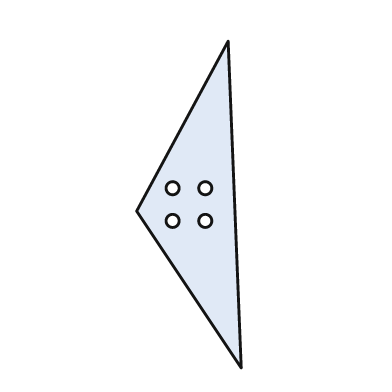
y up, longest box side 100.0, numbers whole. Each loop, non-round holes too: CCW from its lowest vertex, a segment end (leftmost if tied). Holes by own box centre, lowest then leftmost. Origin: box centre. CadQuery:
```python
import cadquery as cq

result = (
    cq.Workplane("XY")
    .moveTo(16.0, -50.0)
    .lineTo(12.0, 50.0)
    .lineTo(-16.0, -2.0)
    .close()
    .moveTo(-5.0, -5.0)
    .circle(2.0)
    .moveTo(5.0, -5.0)
    .circle(2.0)
    .moveTo(-5.0, 5.0)
    .circle(2.0)
    .moveTo(5.0, 5.0)
    .circle(2.0)
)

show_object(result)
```